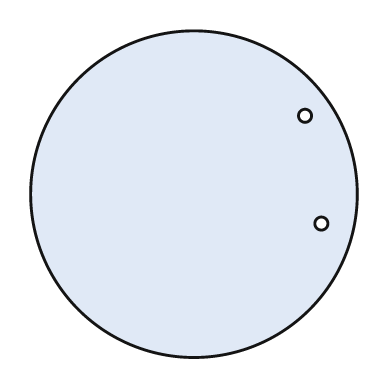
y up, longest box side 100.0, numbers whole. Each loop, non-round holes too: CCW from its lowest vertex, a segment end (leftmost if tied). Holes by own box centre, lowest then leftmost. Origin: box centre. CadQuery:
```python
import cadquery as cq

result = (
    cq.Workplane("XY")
    .moveTo(0.0, 0.0)
    .circle(50.0)
    .moveTo(39.0, -9.0)
    .circle(2.0)
    .moveTo(34.0, 24.0)
    .circle(2.0)
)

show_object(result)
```